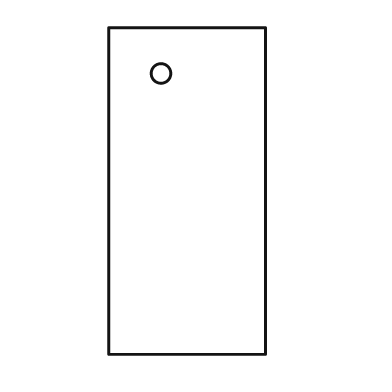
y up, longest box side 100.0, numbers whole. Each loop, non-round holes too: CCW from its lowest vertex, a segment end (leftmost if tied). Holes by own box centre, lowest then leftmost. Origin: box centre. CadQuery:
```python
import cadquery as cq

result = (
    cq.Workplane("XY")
    .moveTo(-24.0, -50.0)
    .lineTo(24.0, -50.0)
    .lineTo(24.0, 50.0)
    .lineTo(-24.0, 50.0)
    .close()
    .moveTo(-8.0, 36.0)
    .circle(3.0)
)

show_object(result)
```